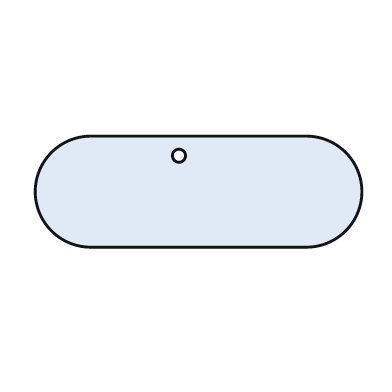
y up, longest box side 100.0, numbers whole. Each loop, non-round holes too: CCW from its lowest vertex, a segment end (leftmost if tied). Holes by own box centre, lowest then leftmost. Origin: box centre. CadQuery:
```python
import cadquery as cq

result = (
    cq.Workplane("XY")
    .moveTo(-33.0, -17.0)
    .lineTo(33.0, -17.0)
    .threePointArc((50.0, 0.0), (33.0, 17.0))
    .lineTo(-33.0, 17.0)
    .threePointArc((-50.0, 0.0), (-33.0, -17.0))
    .close()
    .moveTo(-6.0, 11.0)
    .circle(2.0)
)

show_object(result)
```